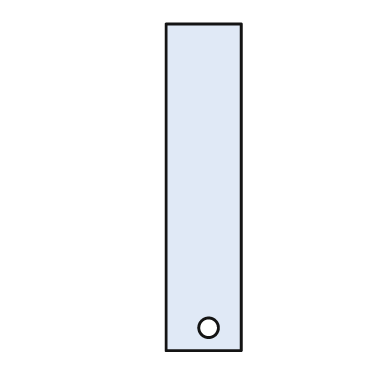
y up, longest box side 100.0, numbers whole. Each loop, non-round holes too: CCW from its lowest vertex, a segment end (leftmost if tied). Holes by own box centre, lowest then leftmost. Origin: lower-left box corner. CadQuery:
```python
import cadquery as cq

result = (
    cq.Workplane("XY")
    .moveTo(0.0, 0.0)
    .lineTo(23.0, 0.0)
    .lineTo(23.0, 100.0)
    .lineTo(0.0, 100.0)
    .close()
    .moveTo(13.0, 7.0)
    .circle(3.0)
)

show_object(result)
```